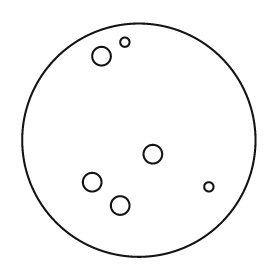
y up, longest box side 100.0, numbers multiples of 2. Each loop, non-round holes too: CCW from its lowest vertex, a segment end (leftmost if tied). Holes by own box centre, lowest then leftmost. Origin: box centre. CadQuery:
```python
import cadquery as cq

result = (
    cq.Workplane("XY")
    .moveTo(0.0, 0.0)
    .circle(50.0)
    .moveTo(-8.0, -28.0)
    .circle(4.0)
    .moveTo(30.0, -20.0)
    .circle(2.0)
    .moveTo(-20.0, -18.0)
    .circle(4.0)
    .moveTo(6.0, -6.0)
    .circle(4.0)
    .moveTo(-16.0, 36.0)
    .circle(4.0)
    .moveTo(-6.0, 42.0)
    .circle(2.0)
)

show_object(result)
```